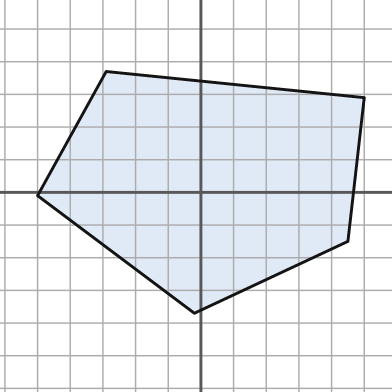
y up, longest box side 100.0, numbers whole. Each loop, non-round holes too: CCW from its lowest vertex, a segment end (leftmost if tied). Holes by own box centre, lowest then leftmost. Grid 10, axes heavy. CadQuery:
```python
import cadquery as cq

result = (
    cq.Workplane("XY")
    .moveTo(-2.0, -37.0)
    .lineTo(45.0, -15.0)
    .lineTo(50.0, 29.0)
    .lineTo(-29.0, 37.0)
    .lineTo(-50.0, -1.0)
    .close()
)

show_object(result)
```